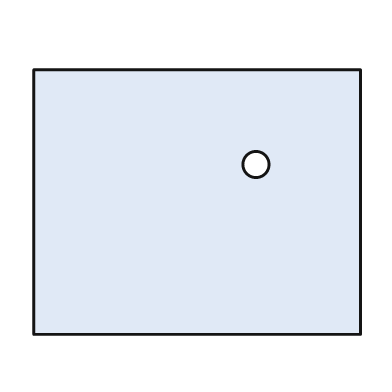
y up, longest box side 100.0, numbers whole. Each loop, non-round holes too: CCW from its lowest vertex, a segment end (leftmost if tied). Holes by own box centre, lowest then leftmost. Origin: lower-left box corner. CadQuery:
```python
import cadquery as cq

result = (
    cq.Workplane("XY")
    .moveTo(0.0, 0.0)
    .lineTo(100.0, 0.0)
    .lineTo(100.0, 81.0)
    .lineTo(0.0, 81.0)
    .close()
    .moveTo(68.0, 52.0)
    .circle(4.0)
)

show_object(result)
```